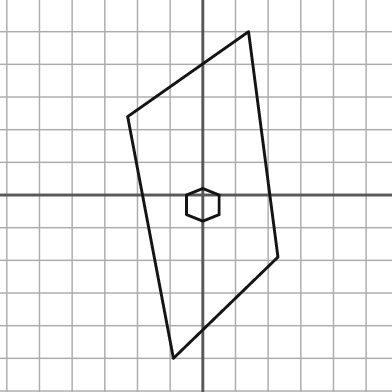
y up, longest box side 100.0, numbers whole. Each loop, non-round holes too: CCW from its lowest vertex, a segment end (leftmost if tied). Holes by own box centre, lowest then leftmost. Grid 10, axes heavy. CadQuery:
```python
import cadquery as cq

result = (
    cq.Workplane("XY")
    .moveTo(-9.0, -50.0)
    .lineTo(23.0, -19.0)
    .lineTo(14.0, 50.0)
    .lineTo(-23.0, 24.0)
    .close()
    .moveTo(0.0, -8.0)
    .lineTo(5.0, -6.0)
    .lineTo(5.0, 0.0)
    .lineTo(0.0, 2.0)
    .lineTo(-5.0, 0.0)
    .lineTo(-5.0, -6.0)
    .close()
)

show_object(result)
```